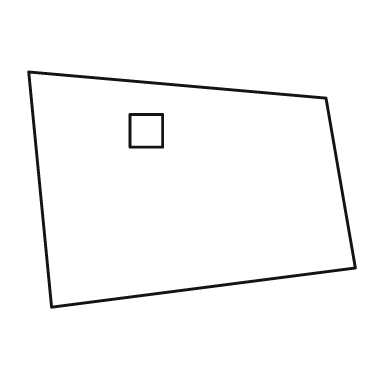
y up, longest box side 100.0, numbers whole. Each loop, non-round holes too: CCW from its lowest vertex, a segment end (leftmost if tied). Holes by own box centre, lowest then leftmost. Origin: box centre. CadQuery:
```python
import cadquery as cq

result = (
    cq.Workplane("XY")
    .moveTo(-43.0, -36.0)
    .lineTo(50.0, -24.0)
    .lineTo(41.0, 28.0)
    .lineTo(-50.0, 36.0)
    .close()
    .moveTo(-19.0, 13.0)
    .lineTo(-9.0, 13.0)
    .lineTo(-9.0, 23.0)
    .lineTo(-19.0, 23.0)
    .close()
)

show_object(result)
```